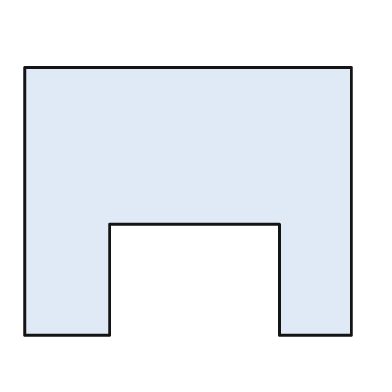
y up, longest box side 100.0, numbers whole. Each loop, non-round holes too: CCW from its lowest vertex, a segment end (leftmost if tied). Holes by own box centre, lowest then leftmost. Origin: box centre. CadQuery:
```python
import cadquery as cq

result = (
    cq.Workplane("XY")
    .moveTo(-50.0, -41.0)
    .lineTo(-24.0, -41.0)
    .lineTo(-24.0, -7.0)
    .lineTo(28.0, -7.0)
    .lineTo(28.0, -41.0)
    .lineTo(50.0, -41.0)
    .lineTo(50.0, 41.0)
    .lineTo(-50.0, 41.0)
    .close()
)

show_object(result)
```